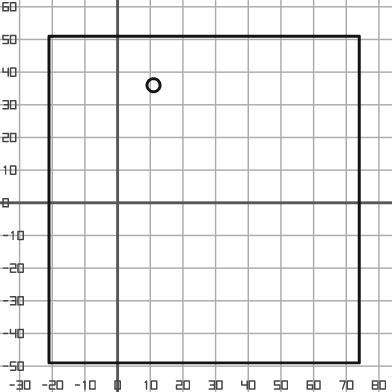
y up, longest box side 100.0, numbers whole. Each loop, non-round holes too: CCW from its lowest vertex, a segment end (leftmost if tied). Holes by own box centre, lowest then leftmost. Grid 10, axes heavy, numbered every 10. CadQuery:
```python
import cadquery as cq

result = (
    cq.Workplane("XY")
    .moveTo(-21.0, -49.0)
    .lineTo(74.0, -49.0)
    .lineTo(74.0, 51.0)
    .lineTo(-21.0, 51.0)
    .close()
    .moveTo(11.0, 36.0)
    .circle(2.0)
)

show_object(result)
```